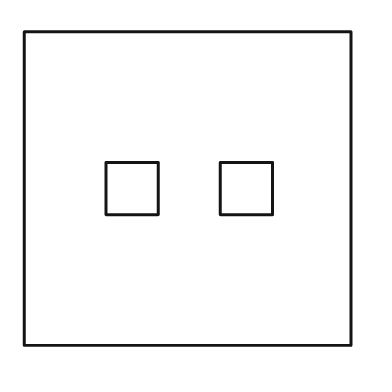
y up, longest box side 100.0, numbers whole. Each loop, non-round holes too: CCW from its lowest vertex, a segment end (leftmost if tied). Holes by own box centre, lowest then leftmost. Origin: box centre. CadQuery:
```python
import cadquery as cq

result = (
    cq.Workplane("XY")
    .moveTo(-50.0, -48.0)
    .lineTo(50.0, -48.0)
    .lineTo(50.0, 48.0)
    .lineTo(-50.0, 48.0)
    .close()
    .moveTo(-25.0, -8.0)
    .lineTo(-9.0, -8.0)
    .lineTo(-9.0, 8.0)
    .lineTo(-25.0, 8.0)
    .close()
    .moveTo(10.0, -8.0)
    .lineTo(26.0, -8.0)
    .lineTo(26.0, 8.0)
    .lineTo(10.0, 8.0)
    .close()
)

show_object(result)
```